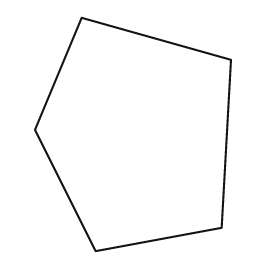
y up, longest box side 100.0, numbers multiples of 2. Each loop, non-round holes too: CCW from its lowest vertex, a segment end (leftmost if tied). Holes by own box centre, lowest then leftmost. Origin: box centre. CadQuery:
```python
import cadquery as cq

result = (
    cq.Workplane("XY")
    .moveTo(-16.0, -50.0)
    .lineTo(38.0, -40.0)
    .lineTo(42.0, 32.0)
    .lineTo(-22.0, 50.0)
    .lineTo(-42.0, 2.0)
    .close()
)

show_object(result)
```